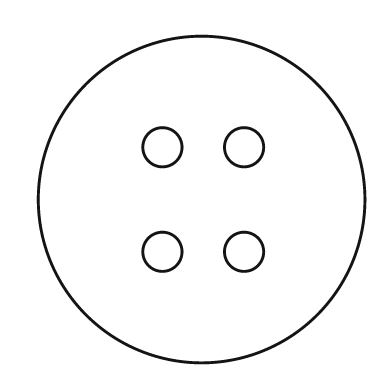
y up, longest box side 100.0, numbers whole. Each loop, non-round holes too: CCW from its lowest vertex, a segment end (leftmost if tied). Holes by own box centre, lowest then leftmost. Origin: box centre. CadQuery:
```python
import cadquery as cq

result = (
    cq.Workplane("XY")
    .moveTo(0.0, 0.0)
    .circle(50.0)
    .moveTo(-12.0, -16.0)
    .circle(6.0)
    .moveTo(13.0, -16.0)
    .circle(6.0)
    .moveTo(-12.0, 16.0)
    .circle(6.0)
    .moveTo(13.0, 16.0)
    .circle(6.0)
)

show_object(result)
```